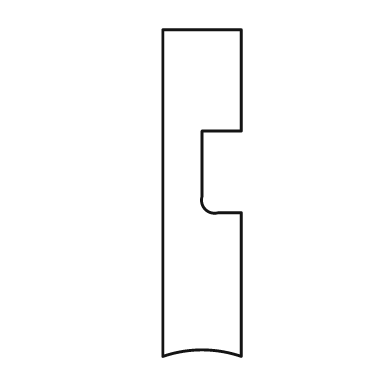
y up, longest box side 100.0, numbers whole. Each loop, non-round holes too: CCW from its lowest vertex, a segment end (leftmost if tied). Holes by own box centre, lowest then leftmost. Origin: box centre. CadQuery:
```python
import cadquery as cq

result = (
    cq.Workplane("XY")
    .moveTo(-12.0, -50.0)
    .threePointArc((0.0, -48.0), (12.0, -50.0))
    .lineTo(12.0, -6.0)
    .lineTo(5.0, -6.0)
    .threePointArc((1.0, -5.0), (0.0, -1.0))
    .lineTo(0.0, 19.0)
    .lineTo(12.0, 19.0)
    .lineTo(12.0, 50.0)
    .lineTo(-12.0, 50.0)
    .close()
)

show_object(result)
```